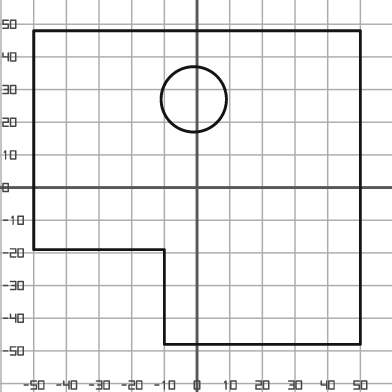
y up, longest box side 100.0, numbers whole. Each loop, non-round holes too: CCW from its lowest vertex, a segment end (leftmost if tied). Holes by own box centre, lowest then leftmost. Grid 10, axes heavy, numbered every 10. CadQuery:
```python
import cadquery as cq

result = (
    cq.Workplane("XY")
    .moveTo(-10.0, -48.0)
    .lineTo(50.0, -48.0)
    .lineTo(50.0, 48.0)
    .lineTo(-50.0, 48.0)
    .lineTo(-50.0, -19.0)
    .lineTo(-10.0, -19.0)
    .close()
    .moveTo(-1.0, 27.0)
    .circle(10.0)
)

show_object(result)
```